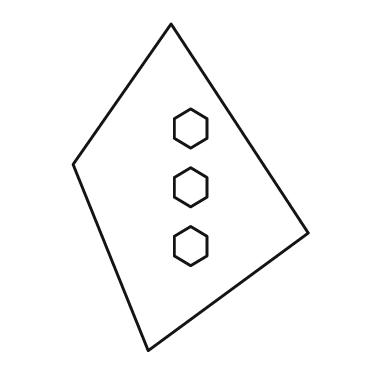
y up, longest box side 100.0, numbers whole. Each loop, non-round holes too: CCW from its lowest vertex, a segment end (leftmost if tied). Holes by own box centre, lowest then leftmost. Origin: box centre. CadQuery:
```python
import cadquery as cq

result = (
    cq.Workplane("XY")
    .moveTo(-13.0, -50.0)
    .lineTo(36.0, -14.0)
    .lineTo(-6.0, 50.0)
    .lineTo(-36.0, 7.0)
    .close()
    .moveTo(0.0, -24.0)
    .lineTo(5.0, -21.0)
    .lineTo(5.0, -15.0)
    .lineTo(0.0, -12.0)
    .lineTo(-5.0, -15.0)
    .lineTo(-5.0, -21.0)
    .close()
    .moveTo(0.0, -6.0)
    .lineTo(5.0, -3.0)
    .lineTo(5.0, 3.0)
    .lineTo(0.0, 6.0)
    .lineTo(-5.0, 3.0)
    .lineTo(-5.0, -3.0)
    .close()
    .moveTo(0.0, 12.0)
    .lineTo(5.0, 15.0)
    .lineTo(5.0, 21.0)
    .lineTo(0.0, 24.0)
    .lineTo(-5.0, 21.0)
    .lineTo(-5.0, 15.0)
    .close()
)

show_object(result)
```